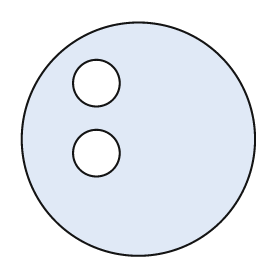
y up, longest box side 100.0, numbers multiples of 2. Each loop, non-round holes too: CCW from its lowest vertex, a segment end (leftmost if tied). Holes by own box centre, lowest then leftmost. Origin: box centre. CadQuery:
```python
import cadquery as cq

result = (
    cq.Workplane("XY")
    .moveTo(0.0, 0.0)
    .circle(50.0)
    .moveTo(-18.0, -6.0)
    .circle(10.0)
    .moveTo(-18.0, 24.0)
    .circle(10.0)
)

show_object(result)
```